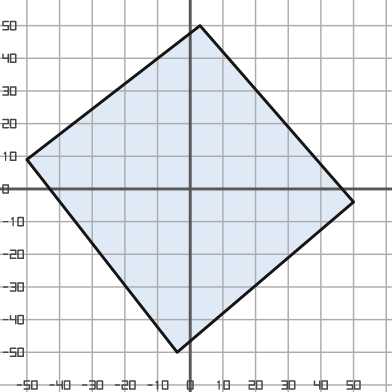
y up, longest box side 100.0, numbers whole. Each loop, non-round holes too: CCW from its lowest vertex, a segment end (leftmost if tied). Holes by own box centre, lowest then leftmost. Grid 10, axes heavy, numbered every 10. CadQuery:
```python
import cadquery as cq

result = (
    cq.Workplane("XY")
    .moveTo(-4.0, -50.0)
    .lineTo(50.0, -4.0)
    .lineTo(3.0, 50.0)
    .lineTo(-50.0, 9.0)
    .close()
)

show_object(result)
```